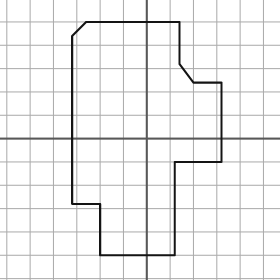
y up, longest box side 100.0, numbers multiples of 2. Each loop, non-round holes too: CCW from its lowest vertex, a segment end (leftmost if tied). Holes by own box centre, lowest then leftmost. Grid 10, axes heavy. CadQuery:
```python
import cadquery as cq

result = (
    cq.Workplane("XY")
    .moveTo(-20.0, -50.0)
    .lineTo(12.0, -50.0)
    .lineTo(12.0, -10.0)
    .lineTo(32.0, -10.0)
    .lineTo(32.0, 24.0)
    .lineTo(20.0, 24.0)
    .lineTo(14.0, 32.0)
    .lineTo(14.0, 50.0)
    .lineTo(-26.0, 50.0)
    .lineTo(-32.0, 44.0)
    .lineTo(-32.0, -28.0)
    .lineTo(-20.0, -28.0)
    .close()
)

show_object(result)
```